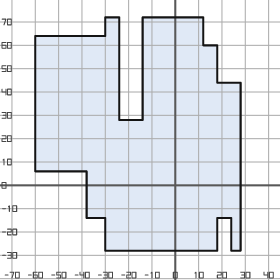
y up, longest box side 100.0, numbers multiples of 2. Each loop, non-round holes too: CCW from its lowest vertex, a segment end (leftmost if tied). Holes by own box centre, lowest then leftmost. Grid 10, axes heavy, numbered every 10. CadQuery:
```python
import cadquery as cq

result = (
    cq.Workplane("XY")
    .moveTo(-30.0, -28.0)
    .lineTo(18.0, -28.0)
    .lineTo(18.0, -14.0)
    .lineTo(24.0, -14.0)
    .lineTo(24.0, -28.0)
    .lineTo(28.0, -28.0)
    .lineTo(28.0, 44.0)
    .lineTo(18.0, 44.0)
    .lineTo(18.0, 60.0)
    .lineTo(12.0, 60.0)
    .lineTo(12.0, 72.0)
    .lineTo(-14.0, 72.0)
    .lineTo(-14.0, 28.0)
    .lineTo(-24.0, 28.0)
    .lineTo(-24.0, 72.0)
    .lineTo(-30.0, 72.0)
    .lineTo(-30.0, 64.0)
    .lineTo(-60.0, 64.0)
    .lineTo(-60.0, 6.0)
    .lineTo(-38.0, 6.0)
    .lineTo(-38.0, -14.0)
    .lineTo(-30.0, -14.0)
    .close()
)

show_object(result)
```